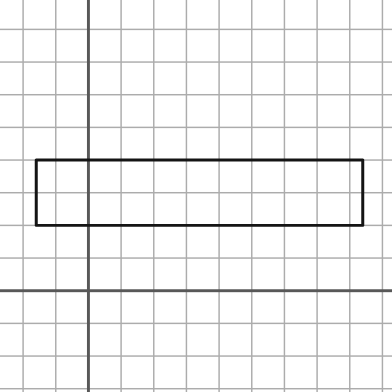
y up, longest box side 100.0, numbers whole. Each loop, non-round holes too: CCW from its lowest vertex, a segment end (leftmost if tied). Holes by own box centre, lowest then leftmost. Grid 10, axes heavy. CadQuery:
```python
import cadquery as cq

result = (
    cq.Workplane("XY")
    .moveTo(-16.0, 20.0)
    .lineTo(84.0, 20.0)
    .lineTo(84.0, 40.0)
    .lineTo(-16.0, 40.0)
    .close()
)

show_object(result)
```